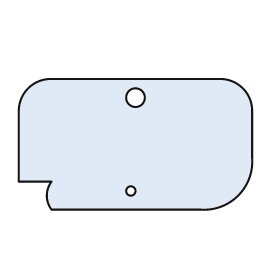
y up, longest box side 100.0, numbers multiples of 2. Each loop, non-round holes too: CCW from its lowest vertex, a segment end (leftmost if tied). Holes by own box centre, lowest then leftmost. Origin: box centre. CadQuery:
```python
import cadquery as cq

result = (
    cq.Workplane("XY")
    .moveTo(-36.0, -28.0)
    .lineTo(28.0, -28.0)
    .threePointArc((44.0, -22.0), (50.0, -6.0))
    .lineTo(50.0, 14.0)
    .threePointArc((46.0, 24.0), (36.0, 28.0))
    .lineTo(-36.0, 28.0)
    .threePointArc((-46.0, 24.0), (-50.0, 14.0))
    .lineTo(-50.0, -16.0)
    .lineTo(-36.0, -16.0)
    .threePointArc((-38.0, -22.0), (-36.0, -28.0))
    .close()
    .moveTo(-2.0, -20.0)
    .circle(2.0)
    .moveTo(0.0, 20.0)
    .circle(4.0)
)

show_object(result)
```